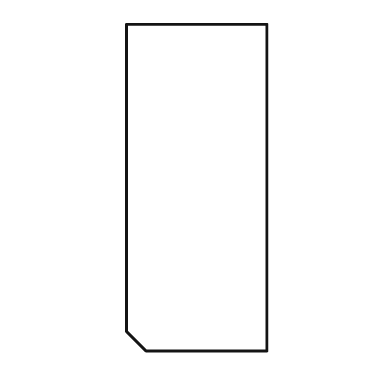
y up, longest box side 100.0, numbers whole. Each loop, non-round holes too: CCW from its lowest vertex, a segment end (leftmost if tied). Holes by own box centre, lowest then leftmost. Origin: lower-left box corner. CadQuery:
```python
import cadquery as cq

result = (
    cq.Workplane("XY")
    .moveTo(6.0, 0.0)
    .lineTo(43.0, 0.0)
    .lineTo(43.0, 100.0)
    .lineTo(0.0, 100.0)
    .lineTo(0.0, 6.0)
    .close()
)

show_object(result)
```